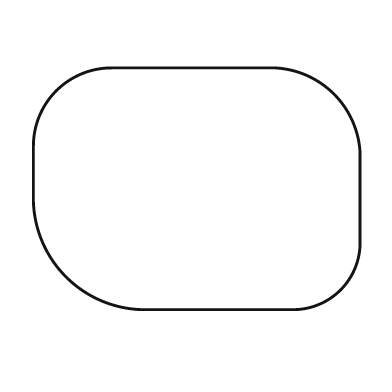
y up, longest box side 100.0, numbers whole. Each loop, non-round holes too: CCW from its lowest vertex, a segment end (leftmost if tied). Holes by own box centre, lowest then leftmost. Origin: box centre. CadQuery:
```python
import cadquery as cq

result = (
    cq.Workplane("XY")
    .moveTo(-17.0, -37.0)
    .lineTo(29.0, -37.0)
    .threePointArc((44.0, -31.0), (50.0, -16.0))
    .lineTo(50.0, 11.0)
    .threePointArc((42.0, 29.0), (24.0, 37.0))
    .lineTo(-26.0, 37.0)
    .threePointArc((-43.0, 30.0), (-50.0, 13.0))
    .lineTo(-50.0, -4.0)
    .threePointArc((-40.0, -27.0), (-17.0, -37.0))
    .close()
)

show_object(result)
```